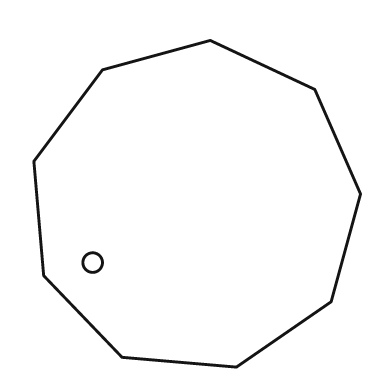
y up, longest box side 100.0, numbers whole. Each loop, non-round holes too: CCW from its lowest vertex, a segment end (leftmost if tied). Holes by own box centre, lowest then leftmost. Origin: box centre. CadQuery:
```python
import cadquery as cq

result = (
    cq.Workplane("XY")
    .moveTo(12.0, -50.0)
    .lineTo(41.0, -30.0)
    .lineTo(50.0, 3.0)
    .lineTo(36.0, 35.0)
    .lineTo(4.0, 50.0)
    .lineTo(-29.0, 41.0)
    .lineTo(-50.0, 13.0)
    .lineTo(-47.0, -22.0)
    .lineTo(-23.0, -47.0)
    .close()
    .moveTo(-32.0, -18.0)
    .circle(3.0)
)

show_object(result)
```